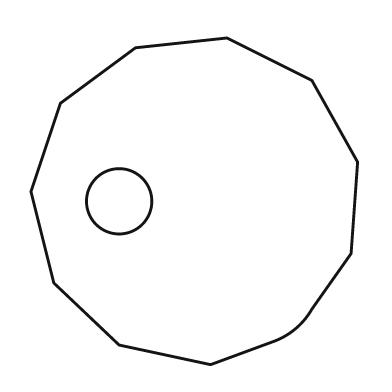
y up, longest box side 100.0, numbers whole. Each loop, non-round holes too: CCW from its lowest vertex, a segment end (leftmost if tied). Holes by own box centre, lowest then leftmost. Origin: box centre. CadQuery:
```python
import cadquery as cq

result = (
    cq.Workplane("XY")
    .moveTo(5.0, -50.0)
    .lineTo(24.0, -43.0)
    .threePointArc((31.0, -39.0), (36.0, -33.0))
    .lineTo(48.0, -16.0)
    .lineTo(50.0, 12.0)
    .lineTo(36.0, 37.0)
    .lineTo(10.0, 50.0)
    .lineTo(-18.0, 47.0)
    .lineTo(-41.0, 30.0)
    .lineTo(-50.0, 3.0)
    .lineTo(-43.0, -25.0)
    .lineTo(-23.0, -44.0)
    .close()
    .moveTo(-23.0, 0.0)
    .circle(10.0)
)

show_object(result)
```